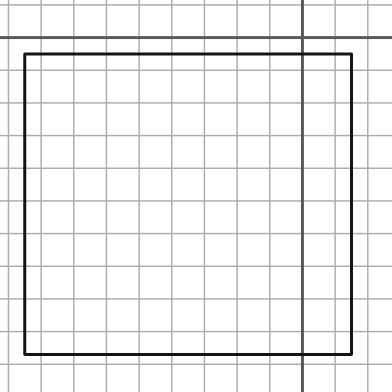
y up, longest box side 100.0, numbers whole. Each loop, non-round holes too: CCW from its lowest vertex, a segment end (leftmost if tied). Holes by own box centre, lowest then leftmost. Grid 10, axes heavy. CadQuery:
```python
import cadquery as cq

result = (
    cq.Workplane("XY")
    .moveTo(-85.0, -97.0)
    .lineTo(15.0, -97.0)
    .lineTo(15.0, -5.0)
    .lineTo(-85.0, -5.0)
    .close()
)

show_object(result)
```